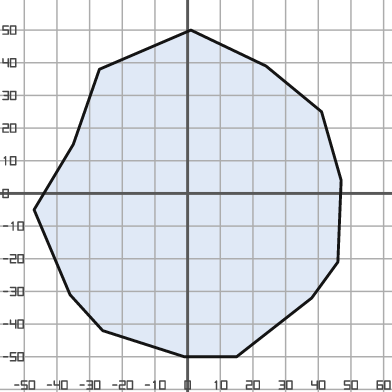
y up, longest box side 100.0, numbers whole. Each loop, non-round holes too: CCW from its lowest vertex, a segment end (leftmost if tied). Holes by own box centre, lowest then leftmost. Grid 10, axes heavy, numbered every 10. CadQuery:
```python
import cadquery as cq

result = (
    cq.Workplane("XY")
    .moveTo(-1.0, -50.0)
    .lineTo(15.0, -50.0)
    .lineTo(38.0, -32.0)
    .lineTo(46.0, -21.0)
    .lineTo(47.0, 4.0)
    .lineTo(41.0, 25.0)
    .lineTo(24.0, 39.0)
    .lineTo(1.0, 50.0)
    .lineTo(-27.0, 38.0)
    .lineTo(-35.0, 15.0)
    .lineTo(-47.0, -5.0)
    .lineTo(-36.0, -31.0)
    .lineTo(-26.0, -42.0)
    .close()
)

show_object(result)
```